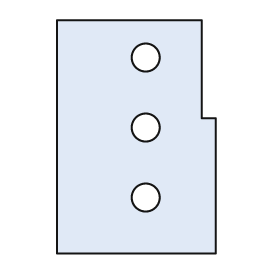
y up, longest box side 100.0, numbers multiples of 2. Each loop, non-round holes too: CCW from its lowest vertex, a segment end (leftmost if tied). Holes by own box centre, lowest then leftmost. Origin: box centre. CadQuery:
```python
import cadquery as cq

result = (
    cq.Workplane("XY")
    .moveTo(-34.0, -50.0)
    .lineTo(34.0, -50.0)
    .lineTo(34.0, 8.0)
    .lineTo(28.0, 8.0)
    .lineTo(28.0, 50.0)
    .lineTo(-34.0, 50.0)
    .close()
    .moveTo(4.0, -26.0)
    .circle(6.0)
    .moveTo(4.0, 4.0)
    .circle(6.0)
    .moveTo(4.0, 34.0)
    .circle(6.0)
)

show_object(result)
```